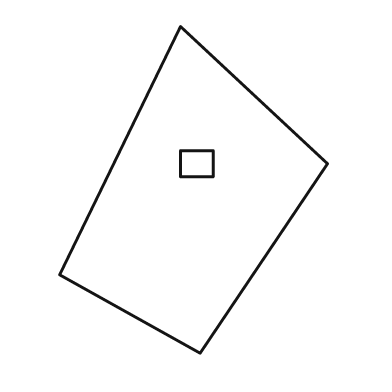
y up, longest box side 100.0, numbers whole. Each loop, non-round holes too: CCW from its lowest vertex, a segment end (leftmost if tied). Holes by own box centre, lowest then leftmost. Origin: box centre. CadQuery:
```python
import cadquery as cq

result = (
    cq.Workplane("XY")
    .moveTo(2.0, -50.0)
    .lineTo(41.0, 8.0)
    .lineTo(-4.0, 50.0)
    .lineTo(-41.0, -26.0)
    .close()
    .moveTo(-4.0, 4.0)
    .lineTo(6.0, 4.0)
    .lineTo(6.0, 12.0)
    .lineTo(-4.0, 12.0)
    .close()
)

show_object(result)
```